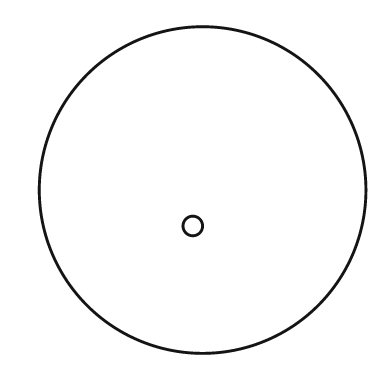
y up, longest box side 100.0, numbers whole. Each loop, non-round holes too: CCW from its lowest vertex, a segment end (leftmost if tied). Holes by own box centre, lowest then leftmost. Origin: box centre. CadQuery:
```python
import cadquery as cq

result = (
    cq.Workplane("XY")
    .moveTo(0.0, 0.0)
    .circle(50.0)
    .moveTo(-3.0, -11.0)
    .circle(3.0)
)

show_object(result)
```